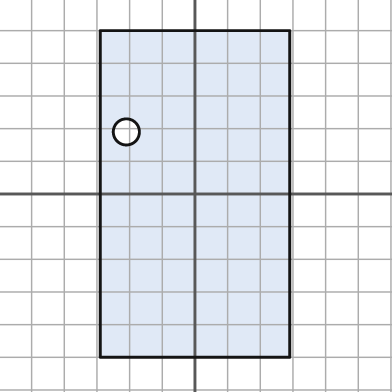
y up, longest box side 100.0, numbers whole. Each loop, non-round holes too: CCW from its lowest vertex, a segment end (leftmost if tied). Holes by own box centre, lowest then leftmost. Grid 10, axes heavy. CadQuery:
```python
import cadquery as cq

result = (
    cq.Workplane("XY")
    .moveTo(-29.0, -50.0)
    .lineTo(29.0, -50.0)
    .lineTo(29.0, 50.0)
    .lineTo(-29.0, 50.0)
    .close()
    .moveTo(-21.0, 19.0)
    .circle(4.0)
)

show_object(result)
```